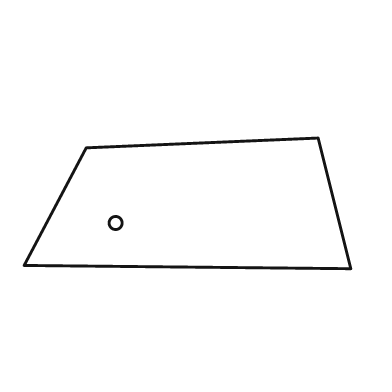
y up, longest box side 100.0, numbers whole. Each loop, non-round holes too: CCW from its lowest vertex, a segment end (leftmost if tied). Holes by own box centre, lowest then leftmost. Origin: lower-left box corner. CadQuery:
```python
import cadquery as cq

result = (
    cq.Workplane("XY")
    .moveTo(100.0, 0.0)
    .lineTo(90.0, 40.0)
    .lineTo(19.0, 37.0)
    .lineTo(0.0, 1.0)
    .close()
    .moveTo(28.0, 14.0)
    .circle(2.0)
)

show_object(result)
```